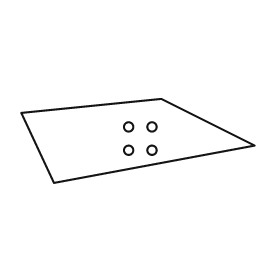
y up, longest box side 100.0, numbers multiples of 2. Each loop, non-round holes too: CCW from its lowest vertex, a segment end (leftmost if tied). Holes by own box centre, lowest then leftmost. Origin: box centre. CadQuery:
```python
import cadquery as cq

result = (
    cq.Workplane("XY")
    .moveTo(-36.0, -18.0)
    .lineTo(50.0, -2.0)
    .lineTo(10.0, 18.0)
    .lineTo(-50.0, 12.0)
    .close()
    .moveTo(-4.0, -4.0)
    .circle(2.0)
    .moveTo(6.0, -4.0)
    .circle(2.0)
    .moveTo(-4.0, 6.0)
    .circle(2.0)
    .moveTo(6.0, 6.0)
    .circle(2.0)
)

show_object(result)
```